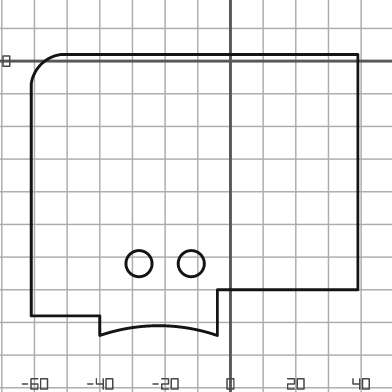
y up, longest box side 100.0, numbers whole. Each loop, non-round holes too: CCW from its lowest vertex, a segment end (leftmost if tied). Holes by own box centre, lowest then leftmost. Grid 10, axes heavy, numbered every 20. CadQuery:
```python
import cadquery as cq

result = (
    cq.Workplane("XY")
    .moveTo(-40.0, -84.0)
    .threePointArc((-22.0, -81.0), (-4.0, -84.0))
    .lineTo(-4.0, -70.0)
    .lineTo(39.0, -70.0)
    .lineTo(39.0, 2.0)
    .lineTo(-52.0, 2.0)
    .threePointArc((-58.0, -1.0), (-61.0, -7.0))
    .lineTo(-61.0, -78.0)
    .lineTo(-40.0, -78.0)
    .close()
    .moveTo(-28.0, -62.0)
    .circle(4.0)
    .moveTo(-12.0, -62.0)
    .circle(4.0)
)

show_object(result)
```